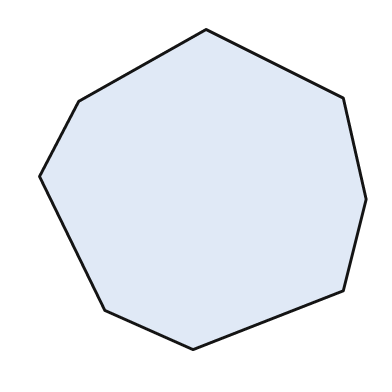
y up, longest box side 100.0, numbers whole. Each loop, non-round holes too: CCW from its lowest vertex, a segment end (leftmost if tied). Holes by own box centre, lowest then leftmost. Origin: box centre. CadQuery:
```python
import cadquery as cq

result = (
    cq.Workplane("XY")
    .moveTo(-3.0, -49.0)
    .lineTo(43.0, -31.0)
    .lineTo(50.0, -3.0)
    .lineTo(43.0, 28.0)
    .lineTo(1.0, 49.0)
    .lineTo(-38.0, 27.0)
    .lineTo(-50.0, 4.0)
    .lineTo(-30.0, -37.0)
    .close()
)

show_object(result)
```